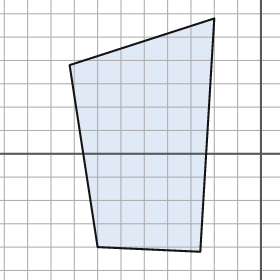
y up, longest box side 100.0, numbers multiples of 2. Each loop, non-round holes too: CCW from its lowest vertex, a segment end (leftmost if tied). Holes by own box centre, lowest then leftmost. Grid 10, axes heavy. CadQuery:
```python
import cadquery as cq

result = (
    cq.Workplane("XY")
    .moveTo(-26.0, -42.0)
    .lineTo(-20.0, 58.0)
    .lineTo(-82.0, 38.0)
    .lineTo(-70.0, -40.0)
    .close()
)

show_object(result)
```